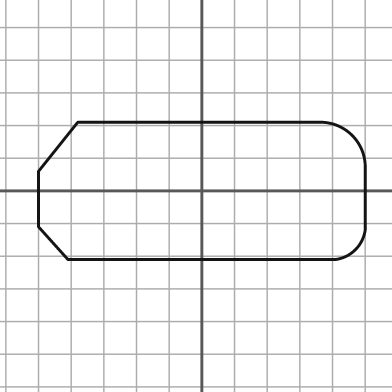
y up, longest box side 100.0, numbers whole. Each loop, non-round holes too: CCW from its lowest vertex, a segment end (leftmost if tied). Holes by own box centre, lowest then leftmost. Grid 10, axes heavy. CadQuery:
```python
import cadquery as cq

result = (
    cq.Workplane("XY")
    .moveTo(-41.0, -21.0)
    .lineTo(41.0, -21.0)
    .threePointArc((47.0, -18.0), (50.0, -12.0))
    .lineTo(50.0, 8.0)
    .threePointArc((46.0, 17.0), (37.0, 21.0))
    .lineTo(-38.0, 21.0)
    .lineTo(-50.0, 6.0)
    .lineTo(-50.0, -11.0)
    .close()
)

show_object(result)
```